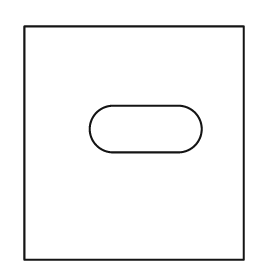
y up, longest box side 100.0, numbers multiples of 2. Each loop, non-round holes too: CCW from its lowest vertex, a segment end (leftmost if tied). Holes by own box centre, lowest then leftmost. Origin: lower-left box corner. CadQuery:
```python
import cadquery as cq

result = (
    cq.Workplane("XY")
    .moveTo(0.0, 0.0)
    .lineTo(94.0, 0.0)
    .lineTo(94.0, 100.0)
    .lineTo(0.0, 100.0)
    .close()
    .moveTo(38.0, 46.0)
    .lineTo(66.0, 46.0)
    .threePointArc((76.0, 56.0), (66.0, 66.0))
    .lineTo(38.0, 66.0)
    .threePointArc((28.0, 56.0), (38.0, 46.0))
    .close()
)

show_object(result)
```